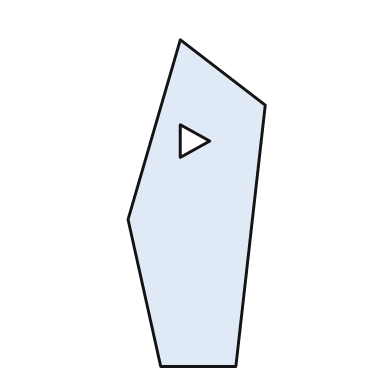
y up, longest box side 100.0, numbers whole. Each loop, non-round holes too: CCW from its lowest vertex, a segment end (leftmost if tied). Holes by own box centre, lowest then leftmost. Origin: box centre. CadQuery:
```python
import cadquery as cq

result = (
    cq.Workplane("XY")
    .moveTo(-11.0, -50.0)
    .lineTo(12.0, -50.0)
    .lineTo(21.0, 30.0)
    .lineTo(-5.0, 50.0)
    .lineTo(-21.0, -5.0)
    .close()
    .moveTo(-5.0, 14.0)
    .lineTo(4.0, 19.0)
    .lineTo(-5.0, 24.0)
    .close()
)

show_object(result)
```